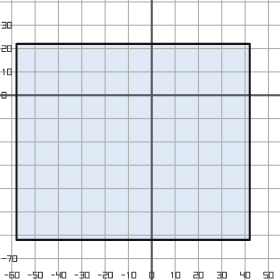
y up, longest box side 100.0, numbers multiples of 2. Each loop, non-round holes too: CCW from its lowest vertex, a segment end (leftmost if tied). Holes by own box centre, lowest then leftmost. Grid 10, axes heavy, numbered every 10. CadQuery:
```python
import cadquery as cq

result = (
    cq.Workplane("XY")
    .moveTo(-58.0, -62.0)
    .lineTo(42.0, -62.0)
    .lineTo(42.0, 22.0)
    .lineTo(-58.0, 22.0)
    .close()
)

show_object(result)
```